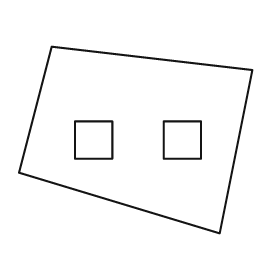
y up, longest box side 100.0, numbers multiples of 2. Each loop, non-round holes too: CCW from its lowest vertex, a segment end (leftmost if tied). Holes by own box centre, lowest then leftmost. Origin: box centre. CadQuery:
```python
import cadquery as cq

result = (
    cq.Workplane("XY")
    .moveTo(36.0, -40.0)
    .lineTo(50.0, 30.0)
    .lineTo(-36.0, 40.0)
    .lineTo(-50.0, -14.0)
    .close()
    .moveTo(-26.0, -8.0)
    .lineTo(-10.0, -8.0)
    .lineTo(-10.0, 8.0)
    .lineTo(-26.0, 8.0)
    .close()
    .moveTo(12.0, -8.0)
    .lineTo(28.0, -8.0)
    .lineTo(28.0, 8.0)
    .lineTo(12.0, 8.0)
    .close()
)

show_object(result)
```